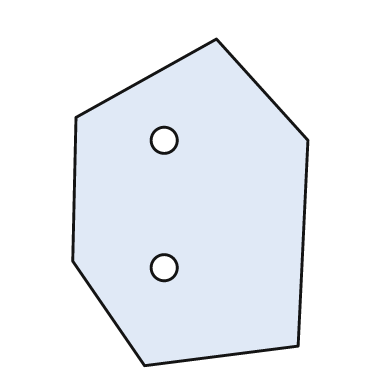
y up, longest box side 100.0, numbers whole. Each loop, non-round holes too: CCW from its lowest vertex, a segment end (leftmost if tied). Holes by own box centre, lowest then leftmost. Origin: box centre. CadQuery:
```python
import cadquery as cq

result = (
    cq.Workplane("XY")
    .moveTo(-14.0, -50.0)
    .lineTo(33.0, -44.0)
    .lineTo(36.0, 19.0)
    .lineTo(8.0, 50.0)
    .lineTo(-35.0, 26.0)
    .lineTo(-36.0, -18.0)
    .close()
    .moveTo(-8.0, -20.0)
    .circle(4.0)
    .moveTo(-8.0, 19.0)
    .circle(4.0)
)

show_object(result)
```